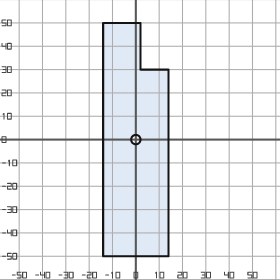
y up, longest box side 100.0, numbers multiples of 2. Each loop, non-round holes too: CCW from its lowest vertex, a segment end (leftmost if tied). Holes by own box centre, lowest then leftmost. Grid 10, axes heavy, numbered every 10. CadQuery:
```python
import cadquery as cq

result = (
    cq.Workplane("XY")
    .moveTo(-14.0, -50.0)
    .lineTo(14.0, -50.0)
    .lineTo(14.0, 30.0)
    .lineTo(2.0, 30.0)
    .lineTo(2.0, 50.0)
    .lineTo(-14.0, 50.0)
    .close()
    .moveTo(0.0, 0.0)
    .circle(2.0)
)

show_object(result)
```